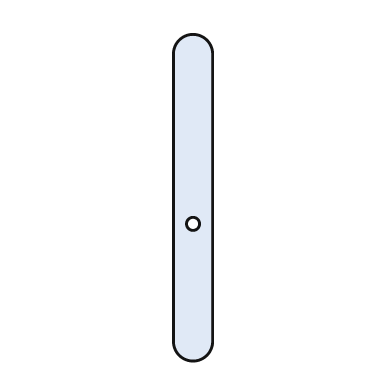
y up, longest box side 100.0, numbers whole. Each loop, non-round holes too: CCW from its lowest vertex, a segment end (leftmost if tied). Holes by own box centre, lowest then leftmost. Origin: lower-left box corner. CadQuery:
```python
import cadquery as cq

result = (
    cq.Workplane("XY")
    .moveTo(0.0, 6.0)
    .threePointArc((6.0, 0.0), (12.0, 6.0))
    .lineTo(12.0, 94.0)
    .threePointArc((6.0, 100.0), (0.0, 94.0))
    .close()
    .moveTo(6.0, 42.0)
    .circle(2.0)
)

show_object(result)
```